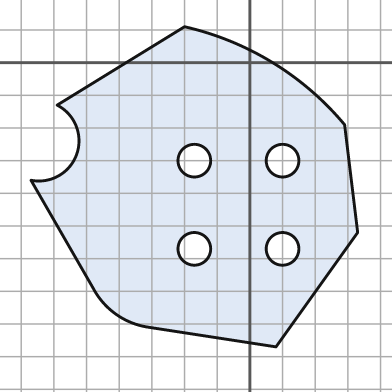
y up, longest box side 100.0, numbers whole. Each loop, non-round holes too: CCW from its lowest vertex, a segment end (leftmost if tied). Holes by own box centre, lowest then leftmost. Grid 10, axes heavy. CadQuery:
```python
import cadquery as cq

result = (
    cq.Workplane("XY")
    .moveTo(8.0, -87.0)
    .lineTo(33.0, -52.0)
    .lineTo(29.0, -19.0)
    .threePointArc((7.0, 0.0), (-20.0, 11.0))
    .lineTo(-59.0, -13.0)
    .threePointArc((-53.0, -28.0), (-67.0, -36.0))
    .lineTo(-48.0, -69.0)
    .threePointArc((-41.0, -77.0), (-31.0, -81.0))
    .close()
    .moveTo(-17.0, -57.0)
    .circle(5.0)
    .moveTo(10.0, -57.0)
    .circle(5.0)
    .moveTo(-17.0, -30.0)
    .circle(5.0)
    .moveTo(10.0, -30.0)
    .circle(5.0)
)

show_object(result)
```